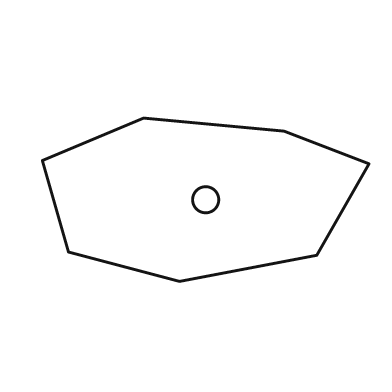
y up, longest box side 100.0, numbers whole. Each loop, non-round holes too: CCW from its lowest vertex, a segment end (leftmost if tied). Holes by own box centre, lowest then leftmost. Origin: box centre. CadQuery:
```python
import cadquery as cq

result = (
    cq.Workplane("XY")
    .moveTo(-8.0, -25.0)
    .lineTo(34.0, -17.0)
    .lineTo(50.0, 11.0)
    .lineTo(24.0, 21.0)
    .lineTo(-19.0, 25.0)
    .lineTo(-50.0, 12.0)
    .lineTo(-42.0, -16.0)
    .close()
    .moveTo(0.0, 0.0)
    .circle(4.0)
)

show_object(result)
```